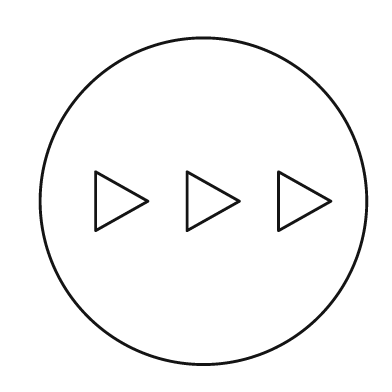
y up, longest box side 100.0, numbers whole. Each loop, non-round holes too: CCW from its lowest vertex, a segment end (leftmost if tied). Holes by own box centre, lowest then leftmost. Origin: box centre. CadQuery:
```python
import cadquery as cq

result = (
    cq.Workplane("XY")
    .moveTo(0.0, 0.0)
    .circle(50.0)
    .moveTo(-33.0, -9.0)
    .lineTo(-17.0, 0.0)
    .lineTo(-33.0, 9.0)
    .close()
    .moveTo(-5.0, -9.0)
    .lineTo(11.0, 0.0)
    .lineTo(-5.0, 9.0)
    .close()
    .moveTo(23.0, -9.0)
    .lineTo(39.0, 0.0)
    .lineTo(23.0, 9.0)
    .close()
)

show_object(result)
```